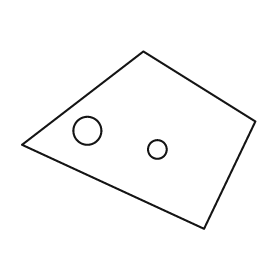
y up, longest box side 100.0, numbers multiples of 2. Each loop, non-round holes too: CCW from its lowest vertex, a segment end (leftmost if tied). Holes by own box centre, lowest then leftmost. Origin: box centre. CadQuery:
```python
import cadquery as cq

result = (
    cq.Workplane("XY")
    .moveTo(28.0, -38.0)
    .lineTo(50.0, 8.0)
    .lineTo(2.0, 38.0)
    .lineTo(-50.0, -2.0)
    .close()
    .moveTo(8.0, -4.0)
    .circle(4.0)
    .moveTo(-22.0, 4.0)
    .circle(6.0)
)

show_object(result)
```